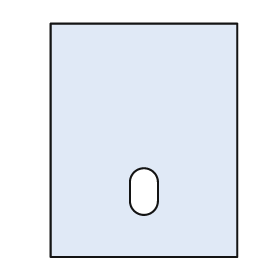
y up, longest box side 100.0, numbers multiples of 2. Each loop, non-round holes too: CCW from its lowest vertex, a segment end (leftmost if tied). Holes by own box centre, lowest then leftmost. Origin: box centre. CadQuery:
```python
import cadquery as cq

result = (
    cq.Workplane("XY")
    .moveTo(-40.0, -50.0)
    .lineTo(40.0, -50.0)
    .lineTo(40.0, 50.0)
    .lineTo(-40.0, 50.0)
    .close()
    .moveTo(-6.0, -26.0)
    .threePointArc((0.0, -32.0), (6.0, -26.0))
    .lineTo(6.0, -18.0)
    .threePointArc((0.0, -12.0), (-6.0, -18.0))
    .close()
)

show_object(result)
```